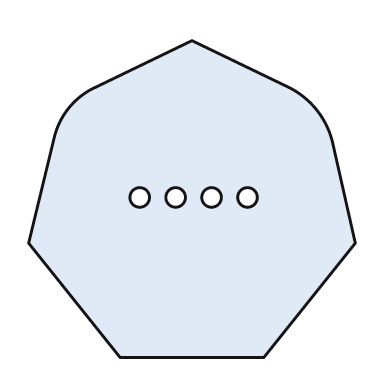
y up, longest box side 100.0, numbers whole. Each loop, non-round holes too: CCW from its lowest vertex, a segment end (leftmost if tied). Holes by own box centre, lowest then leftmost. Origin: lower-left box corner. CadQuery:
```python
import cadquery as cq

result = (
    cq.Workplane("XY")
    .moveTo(28.0, 0.0)
    .lineTo(72.0, 0.0)
    .lineTo(100.0, 35.0)
    .lineTo(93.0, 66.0)
    .threePointArc((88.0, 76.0), (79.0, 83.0))
    .lineTo(50.0, 97.0)
    .lineTo(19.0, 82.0)
    .threePointArc((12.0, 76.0), (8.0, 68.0))
    .lineTo(0.0, 35.0)
    .close()
    .moveTo(34.0, 49.0)
    .circle(3.0)
    .moveTo(45.0, 49.0)
    .circle(3.0)
    .moveTo(56.0, 49.0)
    .circle(3.0)
    .moveTo(67.0, 49.0)
    .circle(3.0)
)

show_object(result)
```